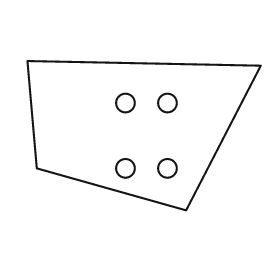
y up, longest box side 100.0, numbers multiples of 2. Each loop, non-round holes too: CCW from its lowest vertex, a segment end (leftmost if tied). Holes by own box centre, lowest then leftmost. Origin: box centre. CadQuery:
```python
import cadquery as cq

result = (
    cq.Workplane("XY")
    .moveTo(18.0, -32.0)
    .lineTo(50.0, 30.0)
    .lineTo(-50.0, 32.0)
    .lineTo(-46.0, -14.0)
    .close()
    .moveTo(-8.0, -14.0)
    .circle(4.0)
    .moveTo(10.0, -14.0)
    .circle(4.0)
    .moveTo(-8.0, 14.0)
    .circle(4.0)
    .moveTo(10.0, 14.0)
    .circle(4.0)
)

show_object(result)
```